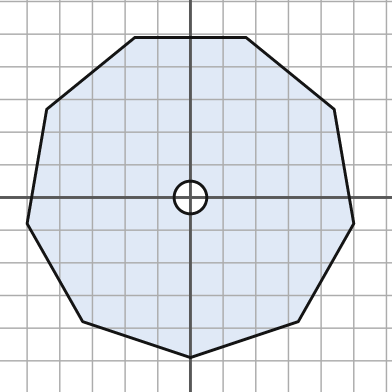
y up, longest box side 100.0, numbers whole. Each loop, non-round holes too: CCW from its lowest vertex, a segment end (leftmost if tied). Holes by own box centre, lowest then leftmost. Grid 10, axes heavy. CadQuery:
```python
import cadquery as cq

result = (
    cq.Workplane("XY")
    .moveTo(0.0, -49.0)
    .lineTo(33.0, -38.0)
    .lineTo(50.0, -8.0)
    .lineTo(44.0, 27.0)
    .lineTo(17.0, 49.0)
    .lineTo(-17.0, 49.0)
    .lineTo(-44.0, 27.0)
    .lineTo(-50.0, -8.0)
    .lineTo(-33.0, -38.0)
    .close()
    .moveTo(0.0, 0.0)
    .circle(5.0)
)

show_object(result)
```